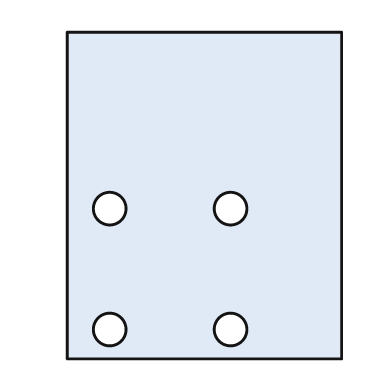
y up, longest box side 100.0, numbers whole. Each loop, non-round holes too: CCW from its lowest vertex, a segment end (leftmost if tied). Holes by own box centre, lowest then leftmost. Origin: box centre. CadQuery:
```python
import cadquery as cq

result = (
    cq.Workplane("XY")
    .moveTo(-42.0, -50.0)
    .lineTo(42.0, -50.0)
    .lineTo(42.0, 50.0)
    .lineTo(-42.0, 50.0)
    .close()
    .moveTo(-29.0, -41.0)
    .circle(5.0)
    .moveTo(8.0, -41.0)
    .circle(5.0)
    .moveTo(-29.0, -4.0)
    .circle(5.0)
    .moveTo(8.0, -4.0)
    .circle(5.0)
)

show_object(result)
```